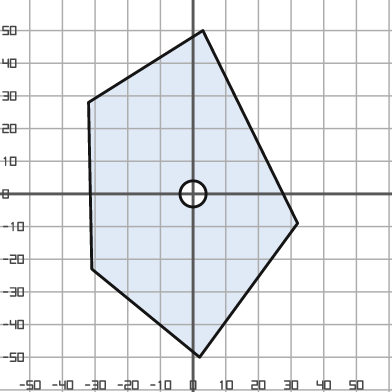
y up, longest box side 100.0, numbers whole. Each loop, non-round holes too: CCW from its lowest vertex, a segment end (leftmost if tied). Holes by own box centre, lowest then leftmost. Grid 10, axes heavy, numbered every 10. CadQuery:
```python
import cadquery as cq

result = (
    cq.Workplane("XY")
    .moveTo(2.0, -50.0)
    .lineTo(32.0, -9.0)
    .lineTo(3.0, 50.0)
    .lineTo(-32.0, 28.0)
    .lineTo(-31.0, -23.0)
    .close()
    .moveTo(0.0, 0.0)
    .circle(4.0)
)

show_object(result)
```